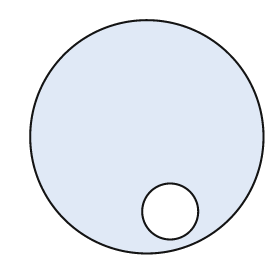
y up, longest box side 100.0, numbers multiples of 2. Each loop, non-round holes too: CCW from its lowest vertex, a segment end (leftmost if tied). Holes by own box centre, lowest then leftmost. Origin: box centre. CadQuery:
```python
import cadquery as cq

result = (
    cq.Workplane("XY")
    .moveTo(0.0, 0.0)
    .circle(50.0)
    .moveTo(10.0, -32.0)
    .circle(12.0)
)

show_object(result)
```